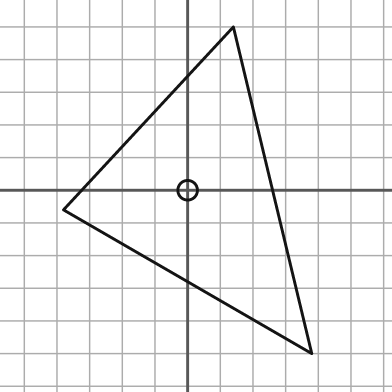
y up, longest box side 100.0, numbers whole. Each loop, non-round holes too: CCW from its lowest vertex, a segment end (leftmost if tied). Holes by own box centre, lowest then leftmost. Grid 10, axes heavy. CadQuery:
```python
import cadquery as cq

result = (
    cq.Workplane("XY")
    .moveTo(38.0, -50.0)
    .lineTo(14.0, 50.0)
    .lineTo(-38.0, -6.0)
    .close()
    .moveTo(0.0, 0.0)
    .circle(3.0)
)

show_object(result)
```